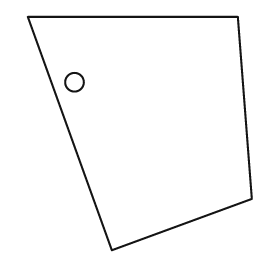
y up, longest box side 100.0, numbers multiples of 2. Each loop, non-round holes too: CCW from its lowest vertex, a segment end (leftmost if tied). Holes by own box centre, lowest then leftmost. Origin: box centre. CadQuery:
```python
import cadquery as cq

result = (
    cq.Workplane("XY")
    .moveTo(-12.0, -50.0)
    .lineTo(48.0, -28.0)
    .lineTo(42.0, 50.0)
    .lineTo(-48.0, 50.0)
    .close()
    .moveTo(-28.0, 22.0)
    .circle(4.0)
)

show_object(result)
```